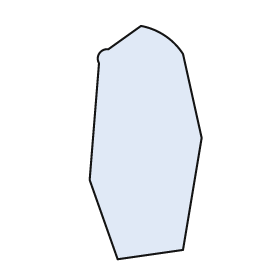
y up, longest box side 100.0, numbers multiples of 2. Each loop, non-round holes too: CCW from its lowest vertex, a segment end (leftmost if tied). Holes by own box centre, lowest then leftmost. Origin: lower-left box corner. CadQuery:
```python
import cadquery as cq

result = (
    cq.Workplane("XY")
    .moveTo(12.0, 0.0)
    .lineTo(40.0, 4.0)
    .lineTo(48.0, 52.0)
    .lineTo(40.0, 88.0)
    .threePointArc((32.0, 96.0), (22.0, 100.0))
    .lineTo(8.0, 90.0)
    .threePointArc((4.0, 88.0), (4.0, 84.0))
    .lineTo(0.0, 34.0)
    .close()
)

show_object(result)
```